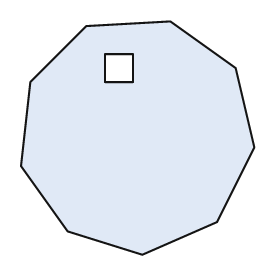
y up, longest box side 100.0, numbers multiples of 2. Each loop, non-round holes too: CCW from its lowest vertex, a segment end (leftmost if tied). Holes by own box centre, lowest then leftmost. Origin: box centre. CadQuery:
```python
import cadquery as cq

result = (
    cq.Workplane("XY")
    .moveTo(2.0, -50.0)
    .lineTo(34.0, -36.0)
    .lineTo(50.0, -4.0)
    .lineTo(42.0, 30.0)
    .lineTo(14.0, 50.0)
    .lineTo(-22.0, 48.0)
    .lineTo(-46.0, 24.0)
    .lineTo(-50.0, -12.0)
    .lineTo(-30.0, -40.0)
    .close()
    .moveTo(-14.0, 24.0)
    .lineTo(-2.0, 24.0)
    .lineTo(-2.0, 36.0)
    .lineTo(-14.0, 36.0)
    .close()
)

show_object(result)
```